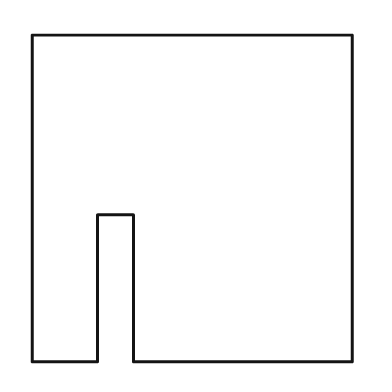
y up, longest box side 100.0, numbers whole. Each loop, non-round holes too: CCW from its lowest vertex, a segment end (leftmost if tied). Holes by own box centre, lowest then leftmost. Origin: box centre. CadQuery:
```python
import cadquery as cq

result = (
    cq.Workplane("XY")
    .moveTo(-49.0, -50.0)
    .lineTo(-29.0, -50.0)
    .lineTo(-29.0, -5.0)
    .lineTo(-18.0, -5.0)
    .lineTo(-18.0, -50.0)
    .lineTo(49.0, -50.0)
    .lineTo(49.0, 50.0)
    .lineTo(-49.0, 50.0)
    .close()
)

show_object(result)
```